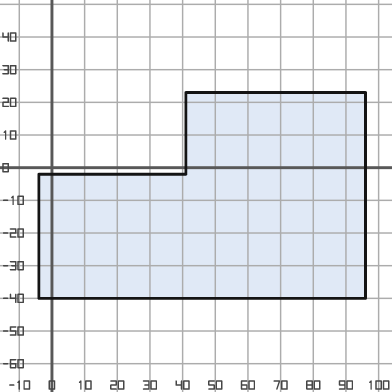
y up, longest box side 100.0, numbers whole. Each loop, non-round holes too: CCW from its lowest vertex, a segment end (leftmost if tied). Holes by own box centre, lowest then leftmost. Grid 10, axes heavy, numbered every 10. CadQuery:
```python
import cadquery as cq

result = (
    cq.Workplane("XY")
    .moveTo(-4.0, -40.0)
    .lineTo(96.0, -40.0)
    .lineTo(96.0, 23.0)
    .lineTo(41.0, 23.0)
    .lineTo(41.0, -2.0)
    .lineTo(-4.0, -2.0)
    .close()
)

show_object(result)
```